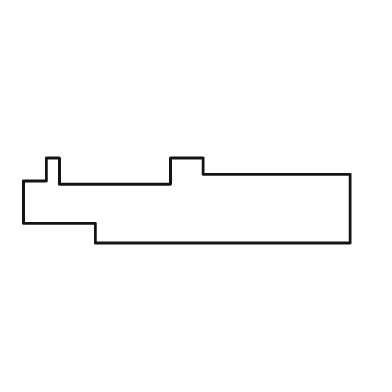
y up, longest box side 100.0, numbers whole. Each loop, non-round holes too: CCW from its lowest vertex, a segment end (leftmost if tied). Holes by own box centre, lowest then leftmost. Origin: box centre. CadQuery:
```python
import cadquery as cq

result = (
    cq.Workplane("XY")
    .moveTo(-28.0, -13.0)
    .lineTo(50.0, -13.0)
    .lineTo(50.0, 8.0)
    .lineTo(5.0, 8.0)
    .lineTo(5.0, 13.0)
    .lineTo(-5.0, 13.0)
    .lineTo(-5.0, 5.0)
    .lineTo(-39.0, 5.0)
    .lineTo(-39.0, 13.0)
    .lineTo(-43.0, 13.0)
    .lineTo(-43.0, 6.0)
    .lineTo(-50.0, 6.0)
    .lineTo(-50.0, -7.0)
    .lineTo(-28.0, -7.0)
    .close()
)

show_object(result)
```